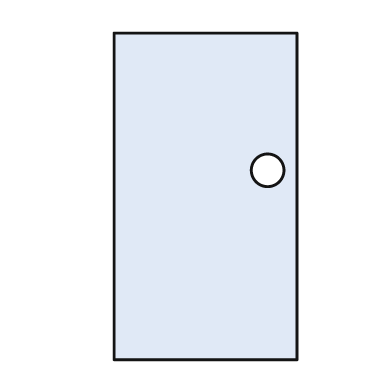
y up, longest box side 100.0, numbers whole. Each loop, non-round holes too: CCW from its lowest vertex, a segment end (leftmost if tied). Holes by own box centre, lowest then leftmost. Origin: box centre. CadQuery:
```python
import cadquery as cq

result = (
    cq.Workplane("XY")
    .moveTo(-28.0, -50.0)
    .lineTo(28.0, -50.0)
    .lineTo(28.0, 50.0)
    .lineTo(-28.0, 50.0)
    .close()
    .moveTo(19.0, 8.0)
    .circle(5.0)
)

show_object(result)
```